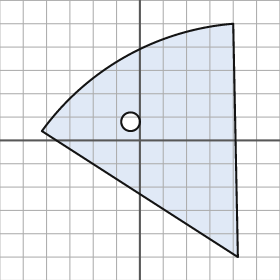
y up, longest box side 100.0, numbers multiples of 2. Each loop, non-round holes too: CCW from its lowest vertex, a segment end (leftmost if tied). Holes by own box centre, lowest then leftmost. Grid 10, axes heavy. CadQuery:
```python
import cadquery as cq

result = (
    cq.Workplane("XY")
    .moveTo(42.0, -50.0)
    .lineTo(40.0, 50.0)
    .threePointArc((-6.0, 36.0), (-42.0, 4.0))
    .close()
    .moveTo(-4.0, 8.0)
    .circle(4.0)
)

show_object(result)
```